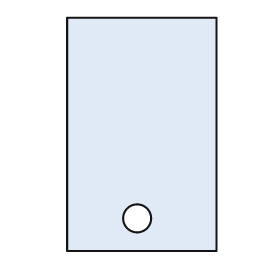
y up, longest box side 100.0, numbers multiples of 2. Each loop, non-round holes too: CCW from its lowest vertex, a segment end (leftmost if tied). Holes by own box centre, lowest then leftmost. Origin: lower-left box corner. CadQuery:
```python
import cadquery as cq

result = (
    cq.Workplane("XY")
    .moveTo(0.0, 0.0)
    .lineTo(64.0, 0.0)
    .lineTo(64.0, 100.0)
    .lineTo(0.0, 100.0)
    .close()
    .moveTo(30.0, 14.0)
    .circle(6.0)
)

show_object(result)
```